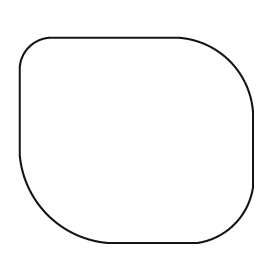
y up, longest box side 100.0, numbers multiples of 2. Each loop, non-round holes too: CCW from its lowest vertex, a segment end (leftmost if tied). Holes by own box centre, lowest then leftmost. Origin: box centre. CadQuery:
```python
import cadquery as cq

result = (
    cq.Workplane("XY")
    .moveTo(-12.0, -44.0)
    .lineTo(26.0, -44.0)
    .threePointArc((42.0, -36.0), (50.0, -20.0))
    .lineTo(50.0, 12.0)
    .threePointArc((40.0, 34.0), (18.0, 44.0))
    .lineTo(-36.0, 44.0)
    .threePointArc((-46.0, 40.0), (-50.0, 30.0))
    .lineTo(-50.0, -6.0)
    .threePointArc((-38.0, -32.0), (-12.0, -44.0))
    .close()
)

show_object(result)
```